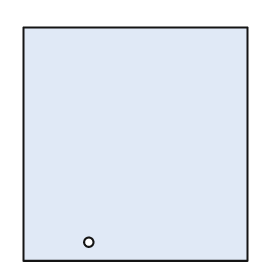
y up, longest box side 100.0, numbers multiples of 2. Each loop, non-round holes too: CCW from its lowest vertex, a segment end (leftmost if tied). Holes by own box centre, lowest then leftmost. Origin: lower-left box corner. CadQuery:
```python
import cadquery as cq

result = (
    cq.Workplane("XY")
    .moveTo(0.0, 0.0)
    .lineTo(96.0, 0.0)
    .lineTo(96.0, 100.0)
    .lineTo(0.0, 100.0)
    .close()
    .moveTo(28.0, 8.0)
    .circle(2.0)
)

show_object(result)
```